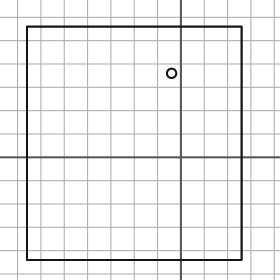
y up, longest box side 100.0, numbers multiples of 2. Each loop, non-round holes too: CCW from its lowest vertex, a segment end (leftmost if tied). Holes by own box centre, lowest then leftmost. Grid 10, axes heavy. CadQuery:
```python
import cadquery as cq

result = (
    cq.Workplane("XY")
    .moveTo(-66.0, -44.0)
    .lineTo(26.0, -44.0)
    .lineTo(26.0, 56.0)
    .lineTo(-66.0, 56.0)
    .close()
    .moveTo(-4.0, 36.0)
    .circle(2.0)
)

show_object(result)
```